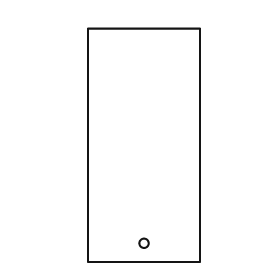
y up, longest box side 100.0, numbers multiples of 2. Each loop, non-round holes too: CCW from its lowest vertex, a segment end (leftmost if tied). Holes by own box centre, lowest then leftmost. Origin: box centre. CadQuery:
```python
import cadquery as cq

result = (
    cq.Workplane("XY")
    .moveTo(-24.0, -50.0)
    .lineTo(24.0, -50.0)
    .lineTo(24.0, 50.0)
    .lineTo(-24.0, 50.0)
    .close()
    .moveTo(0.0, -42.0)
    .circle(2.0)
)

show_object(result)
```